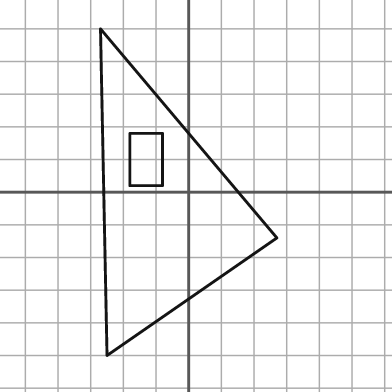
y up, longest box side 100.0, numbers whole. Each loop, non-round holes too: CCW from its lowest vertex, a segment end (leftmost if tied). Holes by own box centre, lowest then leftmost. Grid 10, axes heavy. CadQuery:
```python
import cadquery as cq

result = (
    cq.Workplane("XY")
    .moveTo(-25.0, -50.0)
    .lineTo(27.0, -14.0)
    .lineTo(-27.0, 50.0)
    .close()
    .moveTo(-18.0, 2.0)
    .lineTo(-8.0, 2.0)
    .lineTo(-8.0, 18.0)
    .lineTo(-18.0, 18.0)
    .close()
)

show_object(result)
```